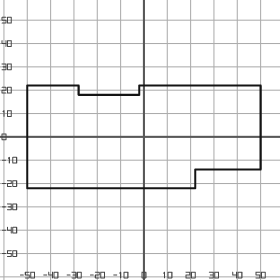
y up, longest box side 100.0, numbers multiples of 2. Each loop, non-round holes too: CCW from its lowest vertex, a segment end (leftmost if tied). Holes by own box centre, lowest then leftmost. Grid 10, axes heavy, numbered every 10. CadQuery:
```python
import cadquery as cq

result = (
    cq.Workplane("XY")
    .moveTo(-50.0, -22.0)
    .lineTo(22.0, -22.0)
    .lineTo(22.0, -14.0)
    .lineTo(50.0, -14.0)
    .lineTo(50.0, 22.0)
    .lineTo(-2.0, 22.0)
    .lineTo(-2.0, 18.0)
    .lineTo(-28.0, 18.0)
    .lineTo(-28.0, 22.0)
    .lineTo(-50.0, 22.0)
    .close()
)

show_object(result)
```